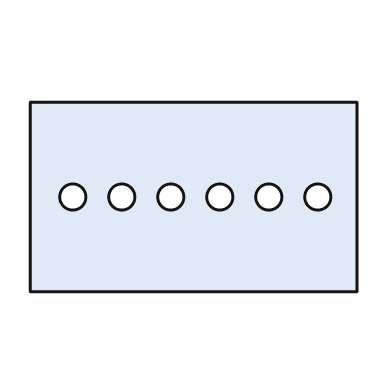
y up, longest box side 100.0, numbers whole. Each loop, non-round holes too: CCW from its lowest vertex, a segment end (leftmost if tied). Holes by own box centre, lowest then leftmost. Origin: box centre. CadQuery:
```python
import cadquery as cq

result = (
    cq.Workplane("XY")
    .moveTo(-50.0, -29.0)
    .lineTo(50.0, -29.0)
    .lineTo(50.0, 29.0)
    .lineTo(-50.0, 29.0)
    .close()
    .moveTo(-37.0, 0.0)
    .circle(4.0)
    .moveTo(-22.0, 0.0)
    .circle(4.0)
    .moveTo(-7.0, 0.0)
    .circle(4.0)
    .moveTo(8.0, 0.0)
    .circle(4.0)
    .moveTo(23.0, 0.0)
    .circle(4.0)
    .moveTo(38.0, 0.0)
    .circle(4.0)
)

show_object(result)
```